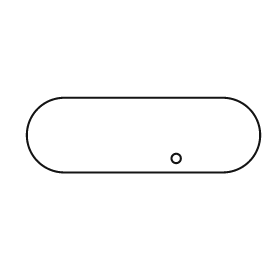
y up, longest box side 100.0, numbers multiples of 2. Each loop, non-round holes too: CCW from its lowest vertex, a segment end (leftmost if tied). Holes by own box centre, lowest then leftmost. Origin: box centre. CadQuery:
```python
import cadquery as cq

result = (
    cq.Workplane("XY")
    .moveTo(-34.0, -16.0)
    .lineTo(34.0, -16.0)
    .threePointArc((50.0, 0.0), (34.0, 16.0))
    .lineTo(-34.0, 16.0)
    .threePointArc((-50.0, 0.0), (-34.0, -16.0))
    .close()
    .moveTo(14.0, -10.0)
    .circle(2.0)
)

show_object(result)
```